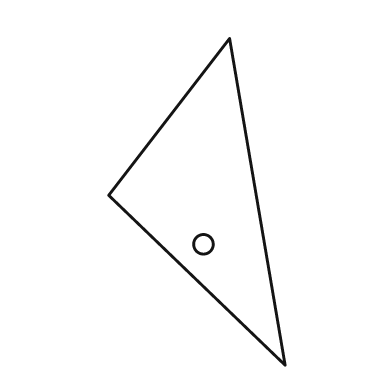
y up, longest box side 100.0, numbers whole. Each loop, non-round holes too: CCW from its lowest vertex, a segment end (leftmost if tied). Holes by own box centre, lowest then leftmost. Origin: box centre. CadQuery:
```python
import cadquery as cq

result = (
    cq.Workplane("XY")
    .moveTo(27.0, -50.0)
    .lineTo(10.0, 50.0)
    .lineTo(-27.0, 2.0)
    .close()
    .moveTo(2.0, -13.0)
    .circle(3.0)
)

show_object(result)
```